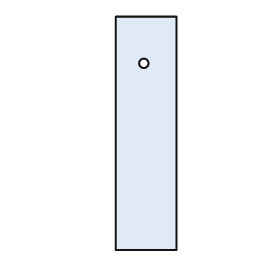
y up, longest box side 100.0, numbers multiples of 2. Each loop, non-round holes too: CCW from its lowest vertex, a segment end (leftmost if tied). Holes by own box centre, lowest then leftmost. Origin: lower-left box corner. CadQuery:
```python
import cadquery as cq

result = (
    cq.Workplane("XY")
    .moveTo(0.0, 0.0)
    .lineTo(26.0, 0.0)
    .lineTo(26.0, 100.0)
    .lineTo(0.0, 100.0)
    .close()
    .moveTo(12.0, 80.0)
    .circle(2.0)
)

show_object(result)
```